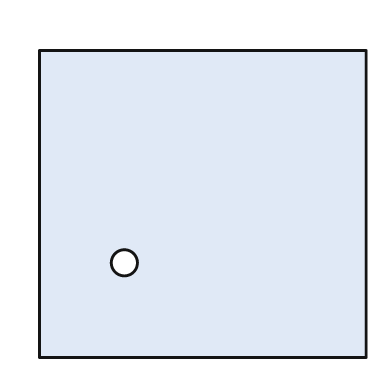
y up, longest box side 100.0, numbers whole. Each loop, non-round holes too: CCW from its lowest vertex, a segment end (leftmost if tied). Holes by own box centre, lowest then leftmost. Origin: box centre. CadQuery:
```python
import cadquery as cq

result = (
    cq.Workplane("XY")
    .moveTo(-50.0, -47.0)
    .lineTo(50.0, -47.0)
    .lineTo(50.0, 47.0)
    .lineTo(-50.0, 47.0)
    .close()
    .moveTo(-24.0, -18.0)
    .circle(4.0)
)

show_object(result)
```